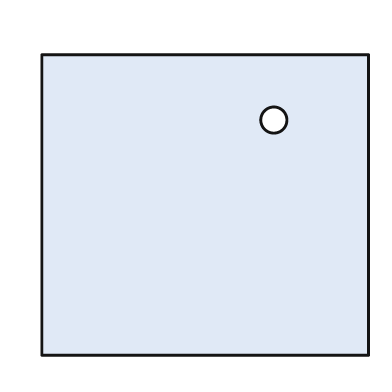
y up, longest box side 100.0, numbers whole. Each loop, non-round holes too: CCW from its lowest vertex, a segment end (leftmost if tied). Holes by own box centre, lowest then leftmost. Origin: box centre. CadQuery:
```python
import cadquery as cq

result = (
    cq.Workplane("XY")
    .moveTo(-50.0, -46.0)
    .lineTo(50.0, -46.0)
    .lineTo(50.0, 46.0)
    .lineTo(-50.0, 46.0)
    .close()
    .moveTo(21.0, 26.0)
    .circle(4.0)
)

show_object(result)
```